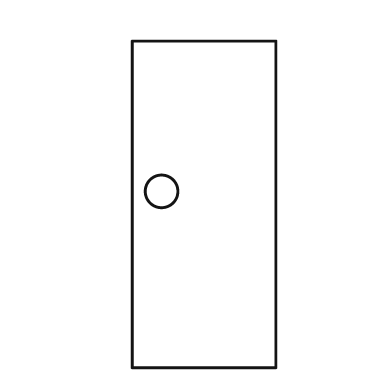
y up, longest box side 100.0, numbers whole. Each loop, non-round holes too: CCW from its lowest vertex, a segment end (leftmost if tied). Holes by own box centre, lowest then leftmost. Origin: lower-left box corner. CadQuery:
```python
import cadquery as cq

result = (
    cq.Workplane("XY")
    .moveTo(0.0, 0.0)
    .lineTo(44.0, 0.0)
    .lineTo(44.0, 100.0)
    .lineTo(0.0, 100.0)
    .close()
    .moveTo(9.0, 54.0)
    .circle(5.0)
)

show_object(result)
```